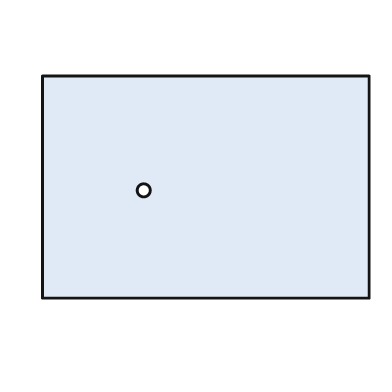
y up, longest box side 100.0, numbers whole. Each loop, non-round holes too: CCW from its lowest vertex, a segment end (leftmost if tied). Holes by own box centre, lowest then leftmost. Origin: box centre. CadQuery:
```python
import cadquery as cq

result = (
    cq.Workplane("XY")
    .moveTo(-50.0, -34.0)
    .lineTo(50.0, -34.0)
    .lineTo(50.0, 34.0)
    .lineTo(-50.0, 34.0)
    .close()
    .moveTo(-19.0, -1.0)
    .circle(2.0)
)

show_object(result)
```